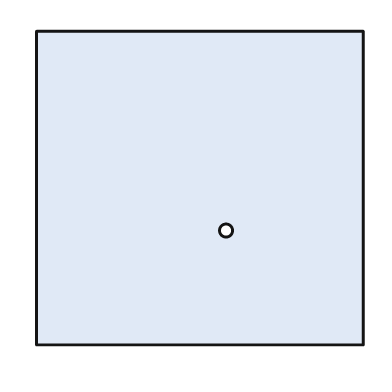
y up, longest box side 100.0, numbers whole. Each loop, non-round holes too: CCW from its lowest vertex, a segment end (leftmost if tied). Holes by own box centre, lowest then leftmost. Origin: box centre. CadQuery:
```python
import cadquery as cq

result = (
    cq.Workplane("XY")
    .moveTo(-50.0, -48.0)
    .lineTo(50.0, -48.0)
    .lineTo(50.0, 48.0)
    .lineTo(-50.0, 48.0)
    .close()
    .moveTo(8.0, -13.0)
    .circle(2.0)
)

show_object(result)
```